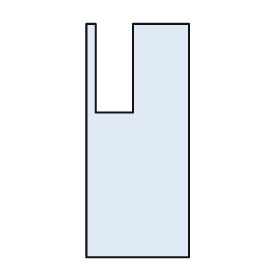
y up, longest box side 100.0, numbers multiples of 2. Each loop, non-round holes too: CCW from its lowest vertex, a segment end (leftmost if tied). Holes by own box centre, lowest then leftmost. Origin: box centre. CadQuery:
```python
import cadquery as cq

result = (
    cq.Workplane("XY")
    .moveTo(-22.0, -50.0)
    .lineTo(22.0, -50.0)
    .lineTo(22.0, 50.0)
    .lineTo(-2.0, 50.0)
    .lineTo(-2.0, 12.0)
    .lineTo(-18.0, 12.0)
    .lineTo(-18.0, 50.0)
    .lineTo(-22.0, 50.0)
    .close()
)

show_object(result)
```